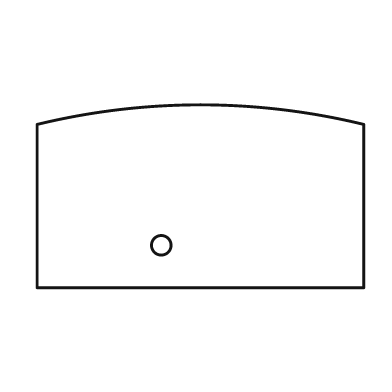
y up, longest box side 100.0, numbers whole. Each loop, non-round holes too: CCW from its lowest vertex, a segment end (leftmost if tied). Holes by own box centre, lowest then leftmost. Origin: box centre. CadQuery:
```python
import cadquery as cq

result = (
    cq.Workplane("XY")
    .moveTo(-50.0, -28.0)
    .lineTo(50.0, -28.0)
    .lineTo(50.0, 22.0)
    .threePointArc((0.0, 28.0), (-50.0, 22.0))
    .close()
    .moveTo(-12.0, -15.0)
    .circle(3.0)
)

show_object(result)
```